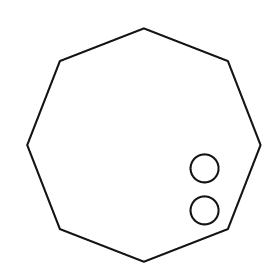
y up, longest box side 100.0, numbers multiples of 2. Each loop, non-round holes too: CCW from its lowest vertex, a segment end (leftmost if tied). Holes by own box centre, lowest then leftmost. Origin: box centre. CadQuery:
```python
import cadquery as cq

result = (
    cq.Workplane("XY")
    .moveTo(0.0, -50.0)
    .lineTo(36.0, -36.0)
    .lineTo(50.0, 0.0)
    .lineTo(36.0, 36.0)
    .lineTo(0.0, 50.0)
    .lineTo(-36.0, 36.0)
    .lineTo(-50.0, 0.0)
    .lineTo(-36.0, -36.0)
    .close()
    .moveTo(26.0, -28.0)
    .circle(6.0)
    .moveTo(26.0, -10.0)
    .circle(6.0)
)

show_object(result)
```